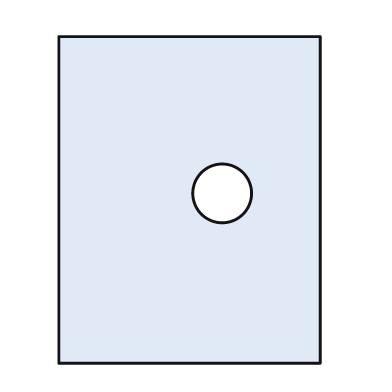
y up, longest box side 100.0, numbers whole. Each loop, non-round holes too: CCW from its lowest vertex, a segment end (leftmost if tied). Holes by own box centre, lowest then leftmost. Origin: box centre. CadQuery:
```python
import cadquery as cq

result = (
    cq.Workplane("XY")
    .moveTo(-40.0, -50.0)
    .lineTo(40.0, -50.0)
    .lineTo(40.0, 50.0)
    .lineTo(-40.0, 50.0)
    .close()
    .moveTo(10.0, 2.0)
    .circle(9.0)
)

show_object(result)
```